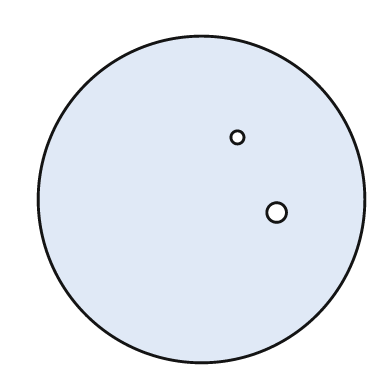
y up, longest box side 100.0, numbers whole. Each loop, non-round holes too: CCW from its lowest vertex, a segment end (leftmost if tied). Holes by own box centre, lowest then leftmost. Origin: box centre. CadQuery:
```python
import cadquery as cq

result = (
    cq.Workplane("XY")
    .moveTo(0.0, 0.0)
    .circle(50.0)
    .moveTo(23.0, -4.0)
    .circle(3.0)
    .moveTo(11.0, 19.0)
    .circle(2.0)
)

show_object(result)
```